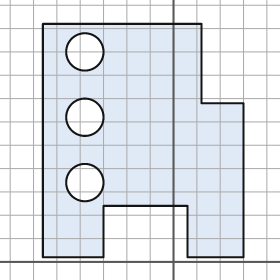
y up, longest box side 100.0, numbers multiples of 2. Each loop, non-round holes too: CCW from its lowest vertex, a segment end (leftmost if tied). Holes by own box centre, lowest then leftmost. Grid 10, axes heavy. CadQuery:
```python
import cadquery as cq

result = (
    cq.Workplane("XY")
    .moveTo(-56.0, 2.0)
    .lineTo(-30.0, 2.0)
    .lineTo(-30.0, 24.0)
    .lineTo(6.0, 24.0)
    .lineTo(6.0, 2.0)
    .lineTo(30.0, 2.0)
    .lineTo(30.0, 68.0)
    .lineTo(12.0, 68.0)
    .lineTo(12.0, 102.0)
    .lineTo(-56.0, 102.0)
    .close()
    .moveTo(-38.0, 34.0)
    .circle(8.0)
    .moveTo(-38.0, 62.0)
    .circle(8.0)
    .moveTo(-38.0, 90.0)
    .circle(8.0)
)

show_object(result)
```